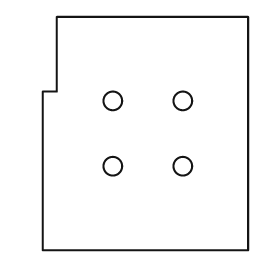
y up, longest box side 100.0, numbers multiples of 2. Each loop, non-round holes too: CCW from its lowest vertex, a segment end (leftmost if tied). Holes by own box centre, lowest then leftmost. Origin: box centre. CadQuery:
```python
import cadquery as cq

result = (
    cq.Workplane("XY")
    .moveTo(-44.0, -50.0)
    .lineTo(44.0, -50.0)
    .lineTo(44.0, 50.0)
    .lineTo(-38.0, 50.0)
    .lineTo(-38.0, 18.0)
    .lineTo(-44.0, 18.0)
    .close()
    .moveTo(-14.0, -14.0)
    .circle(4.0)
    .moveTo(16.0, -14.0)
    .circle(4.0)
    .moveTo(-14.0, 14.0)
    .circle(4.0)
    .moveTo(16.0, 14.0)
    .circle(4.0)
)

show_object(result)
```